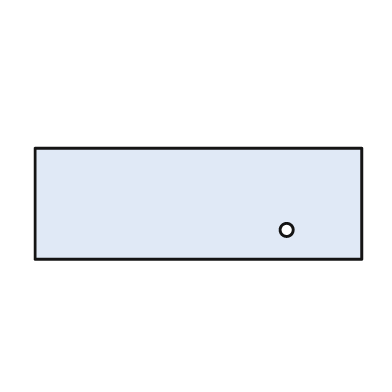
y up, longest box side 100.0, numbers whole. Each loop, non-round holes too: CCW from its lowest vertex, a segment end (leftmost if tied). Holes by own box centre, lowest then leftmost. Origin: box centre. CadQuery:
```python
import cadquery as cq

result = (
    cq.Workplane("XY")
    .moveTo(-50.0, -17.0)
    .lineTo(50.0, -17.0)
    .lineTo(50.0, 17.0)
    .lineTo(-50.0, 17.0)
    .close()
    .moveTo(27.0, -8.0)
    .circle(2.0)
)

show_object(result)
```